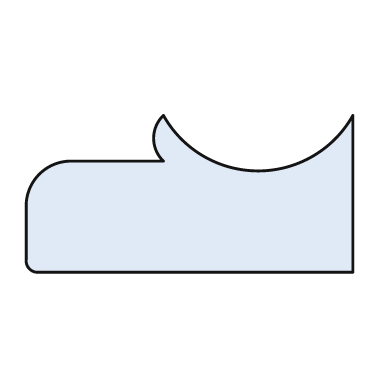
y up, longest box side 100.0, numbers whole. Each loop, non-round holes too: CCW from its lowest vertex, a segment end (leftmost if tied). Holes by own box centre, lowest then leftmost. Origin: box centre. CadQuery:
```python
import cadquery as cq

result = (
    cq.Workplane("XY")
    .moveTo(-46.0, -24.0)
    .lineTo(50.0, -24.0)
    .lineTo(50.0, 24.0)
    .threePointArc((21.0, 7.0), (-8.0, 24.0))
    .threePointArc((-11.0, 17.0), (-8.0, 10.0))
    .lineTo(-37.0, 10.0)
    .threePointArc((-46.0, 6.0), (-50.0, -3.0))
    .lineTo(-50.0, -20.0)
    .threePointArc((-49.0, -23.0), (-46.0, -24.0))
    .close()
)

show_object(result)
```